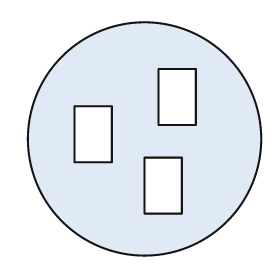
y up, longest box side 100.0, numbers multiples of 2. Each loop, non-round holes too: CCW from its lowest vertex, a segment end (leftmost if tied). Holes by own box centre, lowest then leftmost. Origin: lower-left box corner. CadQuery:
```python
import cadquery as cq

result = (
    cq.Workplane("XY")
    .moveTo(50.0, 50.0)
    .circle(50.0)
    .moveTo(50.0, 18.0)
    .lineTo(66.0, 18.0)
    .lineTo(66.0, 42.0)
    .lineTo(50.0, 42.0)
    .close()
    .moveTo(20.0, 40.0)
    .lineTo(36.0, 40.0)
    .lineTo(36.0, 64.0)
    .lineTo(20.0, 64.0)
    .close()
    .moveTo(56.0, 56.0)
    .lineTo(72.0, 56.0)
    .lineTo(72.0, 80.0)
    .lineTo(56.0, 80.0)
    .close()
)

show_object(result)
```